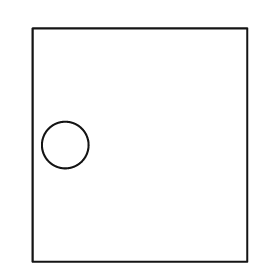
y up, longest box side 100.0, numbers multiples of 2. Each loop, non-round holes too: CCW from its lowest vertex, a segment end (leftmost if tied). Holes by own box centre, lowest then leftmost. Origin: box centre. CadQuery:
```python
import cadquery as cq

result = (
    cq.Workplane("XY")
    .moveTo(-46.0, -50.0)
    .lineTo(46.0, -50.0)
    .lineTo(46.0, 50.0)
    .lineTo(-46.0, 50.0)
    .close()
    .moveTo(-32.0, 0.0)
    .circle(10.0)
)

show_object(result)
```